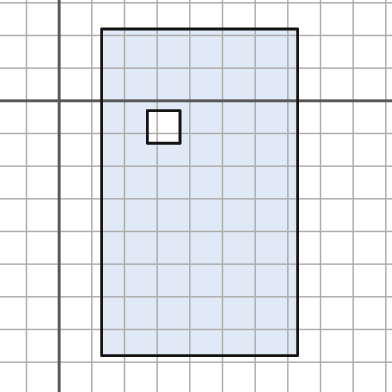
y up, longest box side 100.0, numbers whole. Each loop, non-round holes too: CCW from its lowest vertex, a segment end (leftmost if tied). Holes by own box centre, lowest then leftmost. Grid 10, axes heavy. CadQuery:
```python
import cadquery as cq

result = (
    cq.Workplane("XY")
    .moveTo(13.0, -78.0)
    .lineTo(73.0, -78.0)
    .lineTo(73.0, 22.0)
    .lineTo(13.0, 22.0)
    .close()
    .moveTo(27.0, -13.0)
    .lineTo(37.0, -13.0)
    .lineTo(37.0, -3.0)
    .lineTo(27.0, -3.0)
    .close()
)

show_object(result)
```